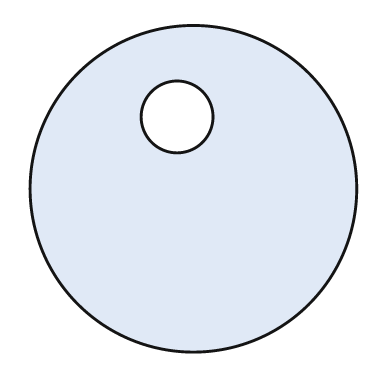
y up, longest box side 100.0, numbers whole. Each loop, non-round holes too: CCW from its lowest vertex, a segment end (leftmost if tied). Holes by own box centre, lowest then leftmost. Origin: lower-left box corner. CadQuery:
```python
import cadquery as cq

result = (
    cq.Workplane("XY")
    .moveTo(50.0, 50.0)
    .circle(50.0)
    .moveTo(45.0, 72.0)
    .circle(11.0)
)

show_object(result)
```